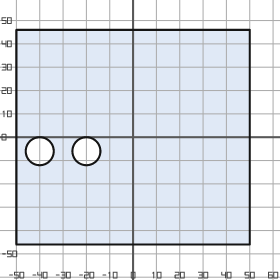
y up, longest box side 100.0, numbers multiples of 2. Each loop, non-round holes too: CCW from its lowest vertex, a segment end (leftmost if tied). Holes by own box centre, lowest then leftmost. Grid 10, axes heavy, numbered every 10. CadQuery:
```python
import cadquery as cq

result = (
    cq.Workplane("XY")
    .moveTo(-50.0, -46.0)
    .lineTo(50.0, -46.0)
    .lineTo(50.0, 46.0)
    .lineTo(-50.0, 46.0)
    .close()
    .moveTo(-40.0, -6.0)
    .circle(6.0)
    .moveTo(-20.0, -6.0)
    .circle(6.0)
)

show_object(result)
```